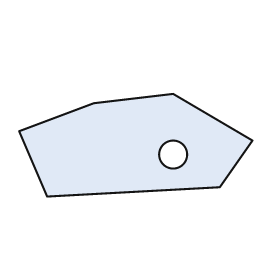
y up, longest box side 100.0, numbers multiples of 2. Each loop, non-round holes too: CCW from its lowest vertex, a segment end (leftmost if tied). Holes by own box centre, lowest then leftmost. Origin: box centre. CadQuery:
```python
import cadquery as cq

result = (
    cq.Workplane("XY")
    .moveTo(-38.0, -22.0)
    .lineTo(36.0, -18.0)
    .lineTo(50.0, 2.0)
    .lineTo(16.0, 22.0)
    .lineTo(-18.0, 18.0)
    .lineTo(-50.0, 6.0)
    .close()
    .moveTo(16.0, -4.0)
    .circle(6.0)
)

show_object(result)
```